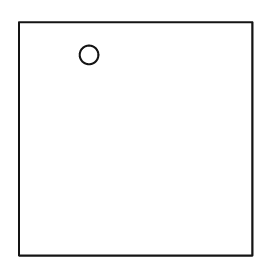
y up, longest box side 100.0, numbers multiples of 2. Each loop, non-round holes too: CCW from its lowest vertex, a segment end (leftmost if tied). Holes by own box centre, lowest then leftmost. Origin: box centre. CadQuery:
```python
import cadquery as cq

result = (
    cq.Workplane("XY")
    .moveTo(-50.0, -50.0)
    .lineTo(50.0, -50.0)
    .lineTo(50.0, 50.0)
    .lineTo(-50.0, 50.0)
    .close()
    .moveTo(-20.0, 36.0)
    .circle(4.0)
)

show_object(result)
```